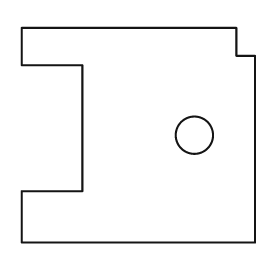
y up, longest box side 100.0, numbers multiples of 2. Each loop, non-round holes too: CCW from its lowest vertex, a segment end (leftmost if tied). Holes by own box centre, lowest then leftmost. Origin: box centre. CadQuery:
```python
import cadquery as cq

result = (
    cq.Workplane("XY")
    .moveTo(-50.0, -46.0)
    .lineTo(50.0, -46.0)
    .lineTo(50.0, 34.0)
    .lineTo(42.0, 34.0)
    .lineTo(42.0, 46.0)
    .lineTo(-50.0, 46.0)
    .lineTo(-50.0, 30.0)
    .lineTo(-24.0, 30.0)
    .lineTo(-24.0, -24.0)
    .lineTo(-50.0, -24.0)
    .close()
    .moveTo(24.0, 0.0)
    .circle(8.0)
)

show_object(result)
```